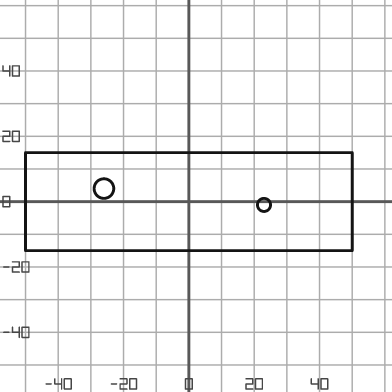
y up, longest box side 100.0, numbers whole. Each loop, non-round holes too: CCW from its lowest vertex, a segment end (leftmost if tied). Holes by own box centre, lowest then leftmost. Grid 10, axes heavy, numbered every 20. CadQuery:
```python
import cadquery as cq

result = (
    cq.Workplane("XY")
    .moveTo(-50.0, -15.0)
    .lineTo(50.0, -15.0)
    .lineTo(50.0, 15.0)
    .lineTo(-50.0, 15.0)
    .close()
    .moveTo(23.0, -1.0)
    .circle(2.0)
    .moveTo(-26.0, 4.0)
    .circle(3.0)
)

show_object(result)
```